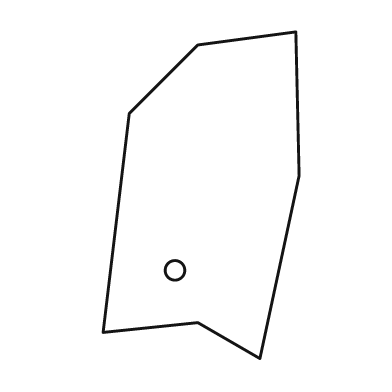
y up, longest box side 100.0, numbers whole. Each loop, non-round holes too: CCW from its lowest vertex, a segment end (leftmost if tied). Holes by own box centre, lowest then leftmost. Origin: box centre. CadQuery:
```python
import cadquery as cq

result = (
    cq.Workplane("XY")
    .moveTo(18.0, -50.0)
    .lineTo(30.0, 6.0)
    .lineTo(29.0, 50.0)
    .lineTo(-1.0, 46.0)
    .lineTo(-22.0, 25.0)
    .lineTo(-30.0, -42.0)
    .lineTo(-1.0, -39.0)
    .close()
    .moveTo(-8.0, -23.0)
    .circle(3.0)
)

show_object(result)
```